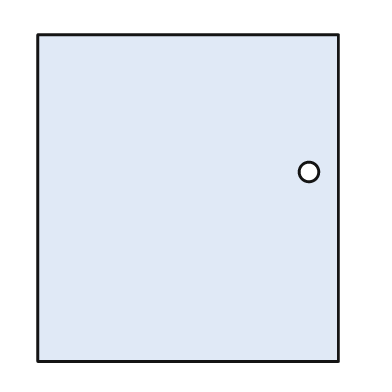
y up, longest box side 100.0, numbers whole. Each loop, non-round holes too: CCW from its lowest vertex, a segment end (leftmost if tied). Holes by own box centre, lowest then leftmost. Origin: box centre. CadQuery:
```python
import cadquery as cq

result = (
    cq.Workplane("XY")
    .moveTo(-46.0, -50.0)
    .lineTo(46.0, -50.0)
    .lineTo(46.0, 50.0)
    .lineTo(-46.0, 50.0)
    .close()
    .moveTo(37.0, 8.0)
    .circle(3.0)
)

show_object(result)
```